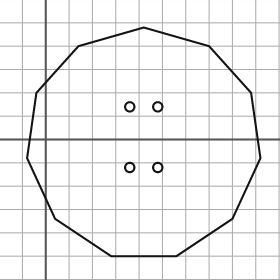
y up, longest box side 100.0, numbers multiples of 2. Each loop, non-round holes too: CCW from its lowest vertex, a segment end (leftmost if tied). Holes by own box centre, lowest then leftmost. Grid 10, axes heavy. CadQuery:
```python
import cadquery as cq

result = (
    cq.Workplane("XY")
    .moveTo(28.0, -50.0)
    .lineTo(56.0, -50.0)
    .lineTo(80.0, -34.0)
    .lineTo(92.0, -8.0)
    .lineTo(88.0, 20.0)
    .lineTo(70.0, 40.0)
    .lineTo(42.0, 48.0)
    .lineTo(14.0, 40.0)
    .lineTo(-4.0, 20.0)
    .lineTo(-8.0, -8.0)
    .lineTo(4.0, -34.0)
    .close()
    .moveTo(36.0, -12.0)
    .circle(2.0)
    .moveTo(48.0, -12.0)
    .circle(2.0)
    .moveTo(36.0, 14.0)
    .circle(2.0)
    .moveTo(48.0, 14.0)
    .circle(2.0)
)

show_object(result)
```